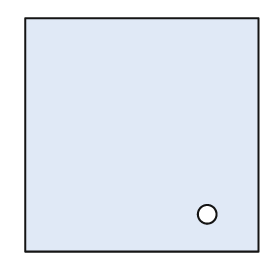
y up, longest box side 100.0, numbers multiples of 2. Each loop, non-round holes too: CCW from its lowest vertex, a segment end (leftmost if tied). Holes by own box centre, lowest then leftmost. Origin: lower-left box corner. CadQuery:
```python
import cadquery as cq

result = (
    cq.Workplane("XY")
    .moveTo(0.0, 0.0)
    .lineTo(100.0, 0.0)
    .lineTo(100.0, 100.0)
    .lineTo(0.0, 100.0)
    .close()
    .moveTo(78.0, 16.0)
    .circle(4.0)
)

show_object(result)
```